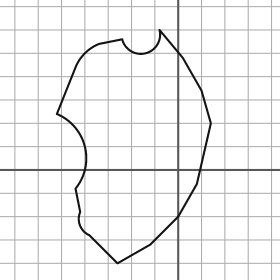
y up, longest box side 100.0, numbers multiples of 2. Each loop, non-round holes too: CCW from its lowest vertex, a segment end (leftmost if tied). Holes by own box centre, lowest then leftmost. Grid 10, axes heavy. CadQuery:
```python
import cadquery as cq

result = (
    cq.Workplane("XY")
    .moveTo(-26.0, -40.0)
    .lineTo(-12.0, -32.0)
    .lineTo(0.0, -20.0)
    .lineTo(8.0, -6.0)
    .lineTo(14.0, 20.0)
    .lineTo(10.0, 34.0)
    .lineTo(2.0, 48.0)
    .lineTo(-8.0, 60.0)
    .threePointArc((-14.0, 50.0), (-24.0, 56.0))
    .lineTo(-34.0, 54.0)
    .threePointArc((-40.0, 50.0), (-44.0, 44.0))
    .lineTo(-52.0, 24.0)
    .threePointArc((-40.0, 10.0), (-44.0, -8.0))
    .lineTo(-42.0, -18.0)
    .threePointArc((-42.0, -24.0), (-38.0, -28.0))
    .close()
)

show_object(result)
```